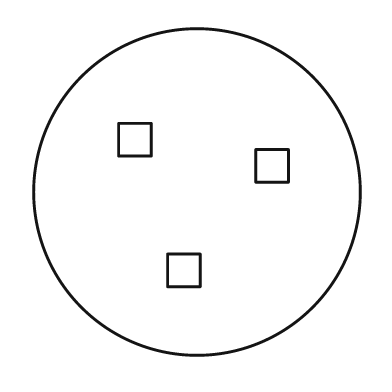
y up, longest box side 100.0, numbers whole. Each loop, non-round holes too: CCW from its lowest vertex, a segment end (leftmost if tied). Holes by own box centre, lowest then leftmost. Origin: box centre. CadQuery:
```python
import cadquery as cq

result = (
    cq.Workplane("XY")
    .moveTo(0.0, 0.0)
    .circle(50.0)
    .moveTo(-9.0, -29.0)
    .lineTo(1.0, -29.0)
    .lineTo(1.0, -19.0)
    .lineTo(-9.0, -19.0)
    .close()
    .moveTo(18.0, 3.0)
    .lineTo(28.0, 3.0)
    .lineTo(28.0, 13.0)
    .lineTo(18.0, 13.0)
    .close()
    .moveTo(-24.0, 11.0)
    .lineTo(-14.0, 11.0)
    .lineTo(-14.0, 21.0)
    .lineTo(-24.0, 21.0)
    .close()
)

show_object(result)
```